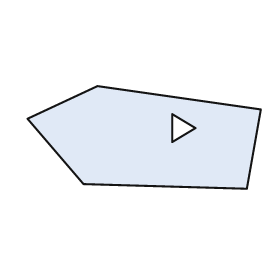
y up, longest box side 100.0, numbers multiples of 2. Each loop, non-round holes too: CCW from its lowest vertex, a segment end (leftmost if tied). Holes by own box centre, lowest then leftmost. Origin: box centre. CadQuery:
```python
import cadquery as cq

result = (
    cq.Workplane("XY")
    .moveTo(44.0, -22.0)
    .lineTo(50.0, 12.0)
    .lineTo(-20.0, 22.0)
    .lineTo(-50.0, 8.0)
    .lineTo(-26.0, -20.0)
    .close()
    .moveTo(12.0, -2.0)
    .lineTo(22.0, 4.0)
    .lineTo(12.0, 10.0)
    .close()
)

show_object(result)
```